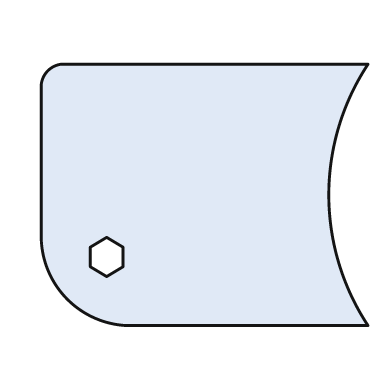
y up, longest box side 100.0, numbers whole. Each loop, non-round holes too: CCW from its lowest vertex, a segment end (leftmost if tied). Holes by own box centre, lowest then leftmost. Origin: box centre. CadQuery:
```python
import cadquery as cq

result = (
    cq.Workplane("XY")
    .moveTo(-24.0, -40.0)
    .lineTo(50.0, -40.0)
    .threePointArc((38.0, 0.0), (50.0, 40.0))
    .lineTo(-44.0, 40.0)
    .threePointArc((-48.0, 38.0), (-50.0, 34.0))
    .lineTo(-50.0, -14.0)
    .threePointArc((-42.0, -32.0), (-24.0, -40.0))
    .close()
    .moveTo(-30.0, -25.0)
    .lineTo(-25.0, -22.0)
    .lineTo(-25.0, -16.0)
    .lineTo(-30.0, -13.0)
    .lineTo(-35.0, -16.0)
    .lineTo(-35.0, -22.0)
    .close()
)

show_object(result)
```